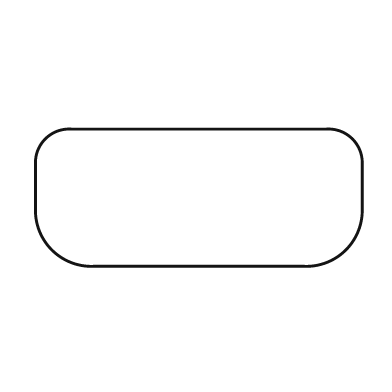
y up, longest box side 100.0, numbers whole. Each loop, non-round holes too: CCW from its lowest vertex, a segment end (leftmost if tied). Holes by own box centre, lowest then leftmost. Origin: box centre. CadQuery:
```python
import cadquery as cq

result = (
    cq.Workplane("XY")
    .moveTo(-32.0, -21.0)
    .lineTo(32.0, -21.0)
    .threePointArc((45.0, -16.0), (50.0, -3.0))
    .lineTo(50.0, 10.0)
    .threePointArc((47.0, 18.0), (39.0, 21.0))
    .lineTo(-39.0, 21.0)
    .threePointArc((-47.0, 18.0), (-50.0, 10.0))
    .lineTo(-50.0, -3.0)
    .threePointArc((-45.0, -16.0), (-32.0, -21.0))
    .close()
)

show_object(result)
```